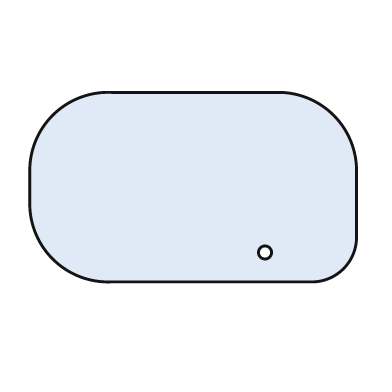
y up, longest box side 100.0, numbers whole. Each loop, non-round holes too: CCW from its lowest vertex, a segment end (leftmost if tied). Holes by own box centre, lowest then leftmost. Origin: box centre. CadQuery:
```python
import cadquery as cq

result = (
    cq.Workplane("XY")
    .moveTo(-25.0, -29.0)
    .lineTo(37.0, -29.0)
    .threePointArc((46.0, -25.0), (50.0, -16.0))
    .lineTo(50.0, 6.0)
    .threePointArc((43.0, 22.0), (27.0, 29.0))
    .lineTo(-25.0, 29.0)
    .threePointArc((-43.0, 22.0), (-50.0, 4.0))
    .lineTo(-50.0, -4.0)
    .threePointArc((-43.0, -22.0), (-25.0, -29.0))
    .close()
    .moveTo(22.0, -20.0)
    .circle(2.0)
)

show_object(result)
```